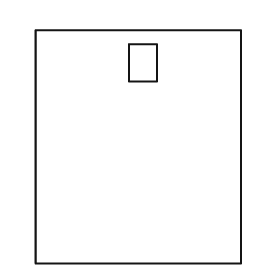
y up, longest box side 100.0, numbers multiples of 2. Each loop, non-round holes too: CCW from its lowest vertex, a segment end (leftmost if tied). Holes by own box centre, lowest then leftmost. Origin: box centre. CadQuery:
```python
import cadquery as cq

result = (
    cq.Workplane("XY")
    .moveTo(-44.0, -50.0)
    .lineTo(44.0, -50.0)
    .lineTo(44.0, 50.0)
    .lineTo(-44.0, 50.0)
    .close()
    .moveTo(-4.0, 28.0)
    .lineTo(8.0, 28.0)
    .lineTo(8.0, 44.0)
    .lineTo(-4.0, 44.0)
    .close()
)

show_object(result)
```